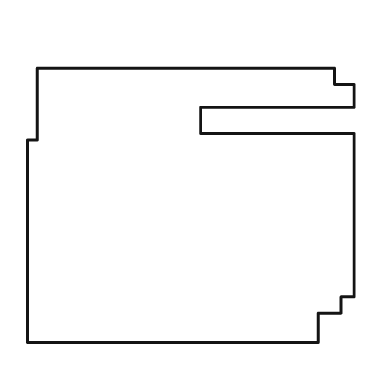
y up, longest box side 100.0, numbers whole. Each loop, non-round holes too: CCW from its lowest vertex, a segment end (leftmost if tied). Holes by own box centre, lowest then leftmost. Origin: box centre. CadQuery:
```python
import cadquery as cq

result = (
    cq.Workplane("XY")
    .moveTo(-50.0, -42.0)
    .lineTo(39.0, -42.0)
    .lineTo(39.0, -33.0)
    .lineTo(46.0, -33.0)
    .lineTo(46.0, -28.0)
    .lineTo(50.0, -28.0)
    .lineTo(50.0, 22.0)
    .lineTo(3.0, 22.0)
    .lineTo(3.0, 30.0)
    .lineTo(50.0, 30.0)
    .lineTo(50.0, 37.0)
    .lineTo(44.0, 37.0)
    .lineTo(44.0, 42.0)
    .lineTo(-47.0, 42.0)
    .lineTo(-47.0, 20.0)
    .lineTo(-50.0, 20.0)
    .close()
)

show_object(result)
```